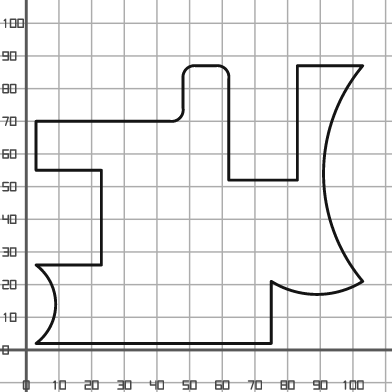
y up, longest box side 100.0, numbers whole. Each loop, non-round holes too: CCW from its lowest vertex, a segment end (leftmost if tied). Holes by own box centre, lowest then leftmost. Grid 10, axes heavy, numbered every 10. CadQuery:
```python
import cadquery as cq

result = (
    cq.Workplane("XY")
    .moveTo(3.0, 2.0)
    .lineTo(75.0, 2.0)
    .lineTo(75.0, 21.0)
    .threePointArc((89.0, 17.0), (103.0, 21.0))
    .threePointArc((91.0, 54.0), (103.0, 87.0))
    .lineTo(83.0, 87.0)
    .lineTo(83.0, 52.0)
    .lineTo(62.0, 52.0)
    .lineTo(62.0, 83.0)
    .threePointArc((61.0, 86.0), (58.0, 87.0))
    .lineTo(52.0, 87.0)
    .threePointArc((49.0, 86.0), (48.0, 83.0))
    .lineTo(48.0, 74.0)
    .threePointArc((47.0, 71.0), (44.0, 70.0))
    .lineTo(3.0, 70.0)
    .lineTo(3.0, 55.0)
    .lineTo(23.0, 55.0)
    .lineTo(23.0, 26.0)
    .lineTo(3.0, 26.0)
    .threePointArc((9.0, 14.0), (3.0, 2.0))
    .close()
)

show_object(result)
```